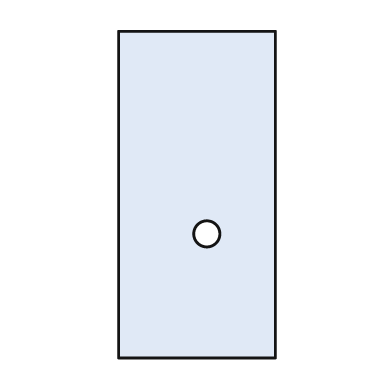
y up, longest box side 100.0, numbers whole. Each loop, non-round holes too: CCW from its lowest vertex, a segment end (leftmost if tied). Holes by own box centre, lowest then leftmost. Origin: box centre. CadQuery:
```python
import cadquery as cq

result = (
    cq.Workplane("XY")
    .moveTo(-24.0, -50.0)
    .lineTo(24.0, -50.0)
    .lineTo(24.0, 50.0)
    .lineTo(-24.0, 50.0)
    .close()
    .moveTo(3.0, -12.0)
    .circle(4.0)
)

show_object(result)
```